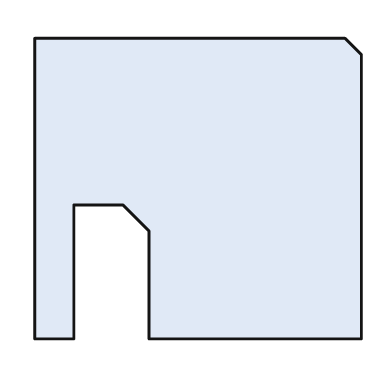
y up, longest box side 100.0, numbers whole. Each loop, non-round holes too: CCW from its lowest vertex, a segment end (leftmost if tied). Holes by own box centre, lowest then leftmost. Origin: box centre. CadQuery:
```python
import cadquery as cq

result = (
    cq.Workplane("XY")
    .moveTo(-50.0, -46.0)
    .lineTo(-38.0, -46.0)
    .lineTo(-38.0, -5.0)
    .lineTo(-23.0, -5.0)
    .lineTo(-15.0, -13.0)
    .lineTo(-15.0, -46.0)
    .lineTo(50.0, -46.0)
    .lineTo(50.0, 41.0)
    .lineTo(45.0, 46.0)
    .lineTo(-50.0, 46.0)
    .close()
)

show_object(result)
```